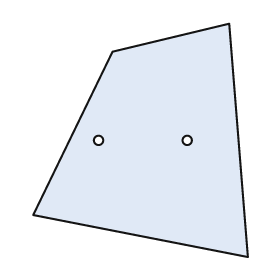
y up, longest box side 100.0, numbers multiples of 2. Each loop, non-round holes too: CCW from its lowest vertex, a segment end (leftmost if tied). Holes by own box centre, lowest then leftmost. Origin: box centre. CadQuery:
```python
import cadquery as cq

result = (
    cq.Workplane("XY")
    .moveTo(46.0, -50.0)
    .lineTo(38.0, 50.0)
    .lineTo(-12.0, 38.0)
    .lineTo(-46.0, -32.0)
    .close()
    .moveTo(-18.0, 0.0)
    .circle(2.0)
    .moveTo(20.0, 0.0)
    .circle(2.0)
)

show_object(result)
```